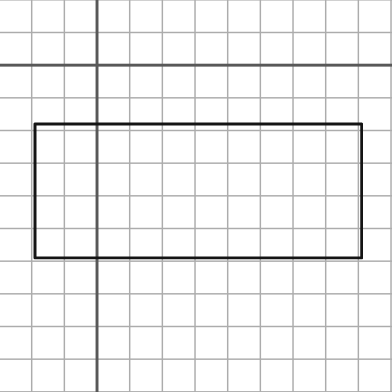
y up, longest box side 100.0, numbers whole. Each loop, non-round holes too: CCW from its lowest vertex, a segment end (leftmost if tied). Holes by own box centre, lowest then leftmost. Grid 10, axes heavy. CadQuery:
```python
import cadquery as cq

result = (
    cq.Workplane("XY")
    .moveTo(-19.0, -59.0)
    .lineTo(81.0, -59.0)
    .lineTo(81.0, -18.0)
    .lineTo(-19.0, -18.0)
    .close()
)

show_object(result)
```